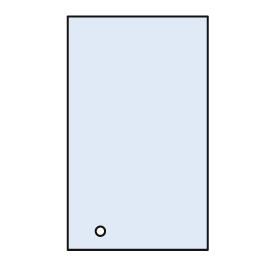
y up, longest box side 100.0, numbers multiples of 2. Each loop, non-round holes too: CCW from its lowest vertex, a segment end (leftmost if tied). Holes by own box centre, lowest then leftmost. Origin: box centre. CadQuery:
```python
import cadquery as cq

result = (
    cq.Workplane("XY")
    .moveTo(-30.0, -50.0)
    .lineTo(30.0, -50.0)
    .lineTo(30.0, 50.0)
    .lineTo(-30.0, 50.0)
    .close()
    .moveTo(-16.0, -42.0)
    .circle(2.0)
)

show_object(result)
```